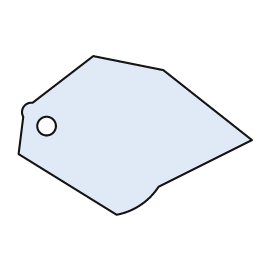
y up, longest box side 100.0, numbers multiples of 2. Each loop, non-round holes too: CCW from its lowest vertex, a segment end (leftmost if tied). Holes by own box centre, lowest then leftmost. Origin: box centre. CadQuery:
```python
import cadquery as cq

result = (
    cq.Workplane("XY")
    .moveTo(-8.0, -34.0)
    .threePointArc((2.0, -30.0), (10.0, -22.0))
    .lineTo(50.0, -2.0)
    .lineTo(12.0, 28.0)
    .lineTo(-18.0, 34.0)
    .lineTo(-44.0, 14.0)
    .threePointArc((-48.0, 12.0), (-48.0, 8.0))
    .lineTo(-50.0, -8.0)
    .close()
    .moveTo(-38.0, 4.0)
    .circle(4.0)
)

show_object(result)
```